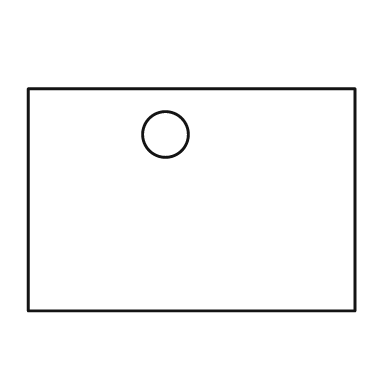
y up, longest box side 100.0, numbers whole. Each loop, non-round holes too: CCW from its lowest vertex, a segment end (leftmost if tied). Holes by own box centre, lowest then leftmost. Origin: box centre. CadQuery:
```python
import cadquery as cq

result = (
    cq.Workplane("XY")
    .moveTo(-50.0, -34.0)
    .lineTo(50.0, -34.0)
    .lineTo(50.0, 34.0)
    .lineTo(-50.0, 34.0)
    .close()
    .moveTo(-8.0, 20.0)
    .circle(7.0)
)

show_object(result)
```